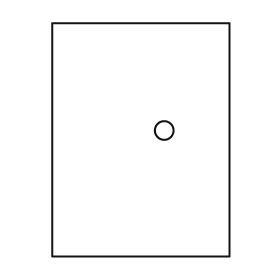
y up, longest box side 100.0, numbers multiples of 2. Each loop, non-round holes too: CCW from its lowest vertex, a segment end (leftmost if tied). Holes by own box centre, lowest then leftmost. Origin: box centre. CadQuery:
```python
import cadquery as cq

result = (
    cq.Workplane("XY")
    .moveTo(-38.0, -50.0)
    .lineTo(38.0, -50.0)
    .lineTo(38.0, 50.0)
    .lineTo(-38.0, 50.0)
    .close()
    .moveTo(10.0, 4.0)
    .circle(4.0)
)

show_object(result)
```